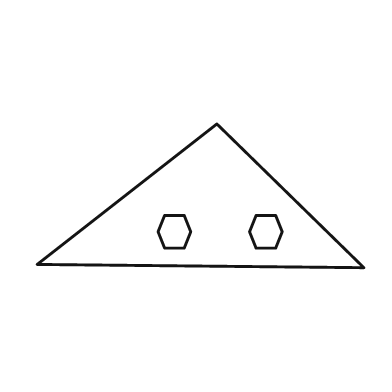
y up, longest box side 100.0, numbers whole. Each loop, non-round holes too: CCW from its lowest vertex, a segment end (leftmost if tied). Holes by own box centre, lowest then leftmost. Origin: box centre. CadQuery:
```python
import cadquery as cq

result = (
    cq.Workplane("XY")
    .moveTo(50.0, -22.0)
    .lineTo(5.0, 22.0)
    .lineTo(-50.0, -21.0)
    .close()
    .moveTo(-11.0, -16.0)
    .lineTo(-5.0, -16.0)
    .lineTo(-3.0, -11.0)
    .lineTo(-5.0, -6.0)
    .lineTo(-11.0, -6.0)
    .lineTo(-13.0, -11.0)
    .close()
    .moveTo(17.0, -16.0)
    .lineTo(23.0, -16.0)
    .lineTo(25.0, -11.0)
    .lineTo(23.0, -6.0)
    .lineTo(17.0, -6.0)
    .lineTo(15.0, -11.0)
    .close()
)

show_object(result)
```